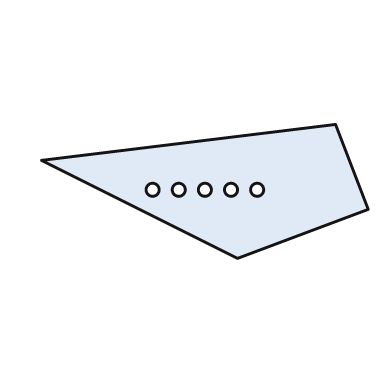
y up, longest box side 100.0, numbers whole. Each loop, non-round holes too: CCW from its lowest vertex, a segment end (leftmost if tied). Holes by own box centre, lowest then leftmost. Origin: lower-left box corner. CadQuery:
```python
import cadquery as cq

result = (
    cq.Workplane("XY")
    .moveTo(60.0, 0.0)
    .lineTo(100.0, 15.0)
    .lineTo(90.0, 41.0)
    .lineTo(0.0, 30.0)
    .close()
    .moveTo(34.0, 21.0)
    .circle(2.0)
    .moveTo(42.0, 21.0)
    .circle(2.0)
    .moveTo(50.0, 21.0)
    .circle(2.0)
    .moveTo(58.0, 21.0)
    .circle(2.0)
    .moveTo(66.0, 21.0)
    .circle(2.0)
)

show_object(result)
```